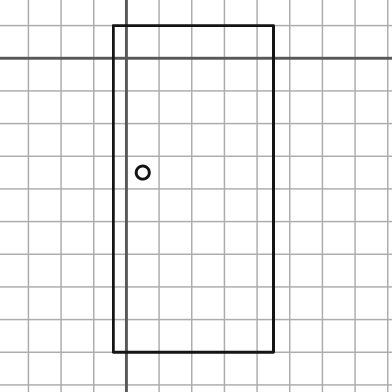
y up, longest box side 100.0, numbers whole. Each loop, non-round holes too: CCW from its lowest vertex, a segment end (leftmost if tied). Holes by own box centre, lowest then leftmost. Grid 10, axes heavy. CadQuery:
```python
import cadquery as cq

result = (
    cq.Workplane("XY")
    .moveTo(-4.0, -90.0)
    .lineTo(45.0, -90.0)
    .lineTo(45.0, 10.0)
    .lineTo(-4.0, 10.0)
    .close()
    .moveTo(5.0, -35.0)
    .circle(2.0)
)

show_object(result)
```